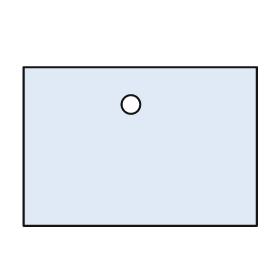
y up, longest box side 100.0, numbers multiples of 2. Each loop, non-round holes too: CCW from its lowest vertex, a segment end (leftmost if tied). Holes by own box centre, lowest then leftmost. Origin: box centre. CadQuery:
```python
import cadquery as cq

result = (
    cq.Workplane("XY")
    .moveTo(-50.0, -34.0)
    .lineTo(50.0, -34.0)
    .lineTo(50.0, 34.0)
    .lineTo(-50.0, 34.0)
    .close()
    .moveTo(-4.0, 18.0)
    .circle(4.0)
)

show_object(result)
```